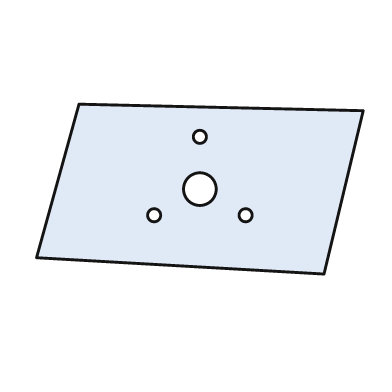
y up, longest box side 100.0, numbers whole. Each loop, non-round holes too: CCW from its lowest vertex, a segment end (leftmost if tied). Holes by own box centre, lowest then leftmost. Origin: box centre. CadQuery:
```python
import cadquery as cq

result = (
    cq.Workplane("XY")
    .moveTo(38.0, -26.0)
    .lineTo(50.0, 24.0)
    .lineTo(-37.0, 26.0)
    .lineTo(-50.0, -21.0)
    .close()
    .moveTo(-14.0, -8.0)
    .circle(2.0)
    .moveTo(14.0, -8.0)
    .circle(2.0)
    .moveTo(0.0, 0.0)
    .circle(5.0)
    .moveTo(0.0, 16.0)
    .circle(2.0)
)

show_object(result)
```